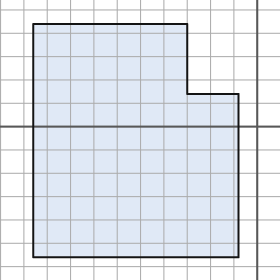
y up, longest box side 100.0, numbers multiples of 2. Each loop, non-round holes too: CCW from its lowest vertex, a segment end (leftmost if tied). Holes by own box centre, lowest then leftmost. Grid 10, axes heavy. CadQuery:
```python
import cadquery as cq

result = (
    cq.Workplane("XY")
    .moveTo(-96.0, -56.0)
    .lineTo(-8.0, -56.0)
    .lineTo(-8.0, 14.0)
    .lineTo(-30.0, 14.0)
    .lineTo(-30.0, 44.0)
    .lineTo(-96.0, 44.0)
    .close()
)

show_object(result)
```